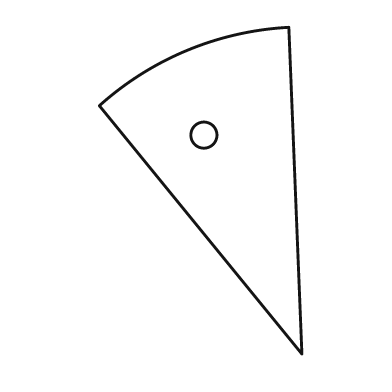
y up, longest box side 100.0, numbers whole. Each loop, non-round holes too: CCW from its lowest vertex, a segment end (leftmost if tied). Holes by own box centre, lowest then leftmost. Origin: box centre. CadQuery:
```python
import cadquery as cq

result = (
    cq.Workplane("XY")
    .moveTo(31.0, -50.0)
    .lineTo(27.0, 50.0)
    .threePointArc((-4.0, 43.0), (-31.0, 26.0))
    .close()
    .moveTo(1.0, 17.0)
    .circle(4.0)
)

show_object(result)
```